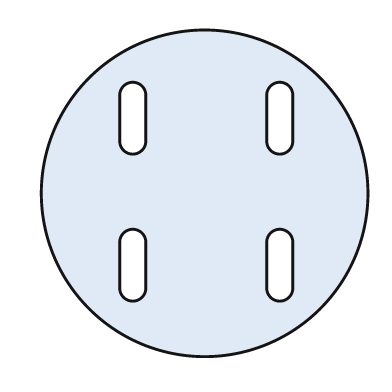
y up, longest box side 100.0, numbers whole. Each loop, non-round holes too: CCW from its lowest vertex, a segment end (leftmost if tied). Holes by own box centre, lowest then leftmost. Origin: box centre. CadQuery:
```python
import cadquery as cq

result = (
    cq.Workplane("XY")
    .moveTo(0.0, 0.0)
    .circle(50.0)
    .moveTo(-26.0, -29.0)
    .threePointArc((-22.0, -33.0), (-18.0, -29.0))
    .lineTo(-18.0, -15.0)
    .threePointArc((-22.0, -11.0), (-26.0, -15.0))
    .close()
    .moveTo(19.0, -29.0)
    .threePointArc((23.0, -33.0), (27.0, -29.0))
    .lineTo(27.0, -15.0)
    .threePointArc((23.0, -11.0), (19.0, -15.0))
    .close()
    .moveTo(-26.0, 16.0)
    .threePointArc((-22.0, 12.0), (-18.0, 16.0))
    .lineTo(-18.0, 30.0)
    .threePointArc((-22.0, 34.0), (-26.0, 30.0))
    .close()
    .moveTo(19.0, 16.0)
    .threePointArc((23.0, 12.0), (27.0, 16.0))
    .lineTo(27.0, 30.0)
    .threePointArc((23.0, 34.0), (19.0, 30.0))
    .close()
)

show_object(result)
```